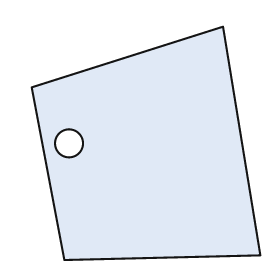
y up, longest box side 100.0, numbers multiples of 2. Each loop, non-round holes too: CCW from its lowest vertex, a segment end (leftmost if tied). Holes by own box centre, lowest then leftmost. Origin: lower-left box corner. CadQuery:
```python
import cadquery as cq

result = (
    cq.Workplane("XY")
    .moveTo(14.0, 0.0)
    .lineTo(98.0, 2.0)
    .lineTo(82.0, 100.0)
    .lineTo(0.0, 74.0)
    .close()
    .moveTo(16.0, 50.0)
    .circle(6.0)
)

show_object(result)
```